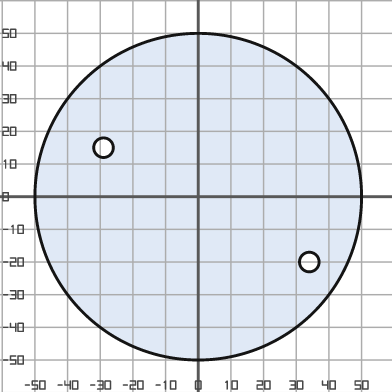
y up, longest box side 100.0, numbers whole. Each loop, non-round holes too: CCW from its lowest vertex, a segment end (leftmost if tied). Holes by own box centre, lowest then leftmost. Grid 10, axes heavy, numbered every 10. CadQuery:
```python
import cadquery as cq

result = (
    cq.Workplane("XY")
    .moveTo(0.0, 0.0)
    .circle(50.0)
    .moveTo(34.0, -20.0)
    .circle(3.0)
    .moveTo(-29.0, 15.0)
    .circle(3.0)
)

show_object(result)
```